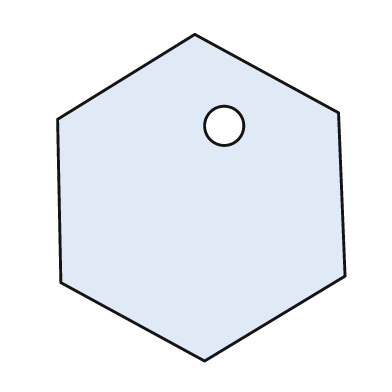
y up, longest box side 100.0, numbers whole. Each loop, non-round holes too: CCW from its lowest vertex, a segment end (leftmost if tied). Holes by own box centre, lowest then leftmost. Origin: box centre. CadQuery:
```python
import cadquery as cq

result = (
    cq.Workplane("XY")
    .moveTo(1.0, -50.0)
    .lineTo(44.0, -24.0)
    .lineTo(42.0, 26.0)
    .lineTo(-2.0, 50.0)
    .lineTo(-44.0, 24.0)
    .lineTo(-43.0, -26.0)
    .close()
    .moveTo(7.0, 22.0)
    .circle(6.0)
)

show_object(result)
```